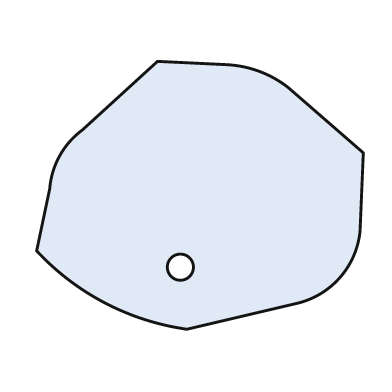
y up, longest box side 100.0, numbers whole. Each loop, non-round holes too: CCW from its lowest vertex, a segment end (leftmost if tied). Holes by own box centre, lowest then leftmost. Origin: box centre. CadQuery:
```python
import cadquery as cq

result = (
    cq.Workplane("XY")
    .moveTo(-4.0, -41.0)
    .lineTo(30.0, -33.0)
    .threePointArc((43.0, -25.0), (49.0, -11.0))
    .lineTo(50.0, 13.0)
    .lineTo(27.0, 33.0)
    .threePointArc((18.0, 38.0), (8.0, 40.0))
    .lineTo(-13.0, 41.0)
    .lineTo(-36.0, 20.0)
    .threePointArc((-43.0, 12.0), (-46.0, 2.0))
    .lineTo(-50.0, -17.0)
    .threePointArc((-29.0, -33.0), (-4.0, -41.0))
    .close()
    .moveTo(-6.0, -22.0)
    .circle(4.0)
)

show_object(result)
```